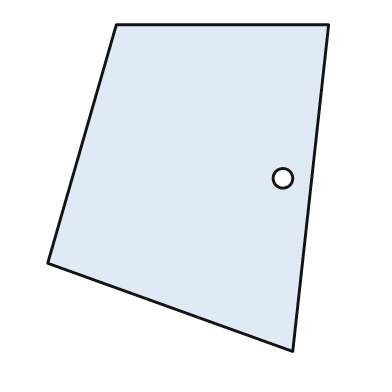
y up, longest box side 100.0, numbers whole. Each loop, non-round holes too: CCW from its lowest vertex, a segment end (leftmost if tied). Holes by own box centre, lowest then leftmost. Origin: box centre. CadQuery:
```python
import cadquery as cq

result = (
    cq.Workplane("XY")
    .moveTo(32.0, -50.0)
    .lineTo(43.0, 50.0)
    .lineTo(-22.0, 50.0)
    .lineTo(-43.0, -23.0)
    .close()
    .moveTo(29.0, 3.0)
    .circle(3.0)
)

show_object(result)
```